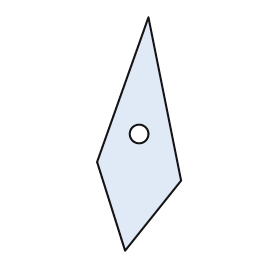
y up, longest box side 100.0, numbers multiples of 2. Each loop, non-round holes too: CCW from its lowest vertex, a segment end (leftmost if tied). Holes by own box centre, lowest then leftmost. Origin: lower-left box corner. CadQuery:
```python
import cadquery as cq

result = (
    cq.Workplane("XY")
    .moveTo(12.0, 0.0)
    .lineTo(36.0, 30.0)
    .lineTo(22.0, 100.0)
    .lineTo(0.0, 38.0)
    .close()
    .moveTo(18.0, 50.0)
    .circle(4.0)
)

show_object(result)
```